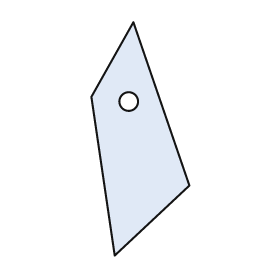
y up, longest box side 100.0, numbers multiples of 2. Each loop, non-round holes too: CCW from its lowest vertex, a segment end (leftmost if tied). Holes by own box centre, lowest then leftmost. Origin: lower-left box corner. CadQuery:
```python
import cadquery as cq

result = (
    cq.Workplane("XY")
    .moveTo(10.0, 0.0)
    .lineTo(42.0, 30.0)
    .lineTo(18.0, 100.0)
    .lineTo(0.0, 68.0)
    .close()
    .moveTo(16.0, 66.0)
    .circle(4.0)
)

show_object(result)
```